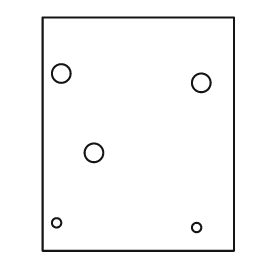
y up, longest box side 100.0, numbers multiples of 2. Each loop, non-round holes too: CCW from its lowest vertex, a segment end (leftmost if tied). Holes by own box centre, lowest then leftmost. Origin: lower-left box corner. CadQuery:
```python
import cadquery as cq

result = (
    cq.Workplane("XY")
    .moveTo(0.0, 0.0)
    .lineTo(82.0, 0.0)
    .lineTo(82.0, 100.0)
    .lineTo(0.0, 100.0)
    .close()
    .moveTo(66.0, 10.0)
    .circle(2.0)
    .moveTo(6.0, 12.0)
    .circle(2.0)
    .moveTo(22.0, 42.0)
    .circle(4.0)
    .moveTo(68.0, 72.0)
    .circle(4.0)
    .moveTo(8.0, 76.0)
    .circle(4.0)
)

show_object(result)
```